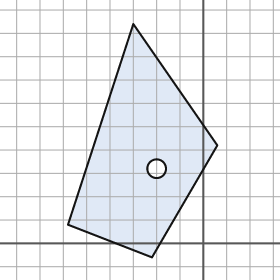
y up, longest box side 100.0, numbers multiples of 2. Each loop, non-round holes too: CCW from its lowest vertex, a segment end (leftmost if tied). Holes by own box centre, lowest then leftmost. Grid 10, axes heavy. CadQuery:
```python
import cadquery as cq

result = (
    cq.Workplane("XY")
    .moveTo(-22.0, -6.0)
    .lineTo(6.0, 42.0)
    .lineTo(-30.0, 94.0)
    .lineTo(-58.0, 8.0)
    .close()
    .moveTo(-20.0, 32.0)
    .circle(4.0)
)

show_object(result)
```